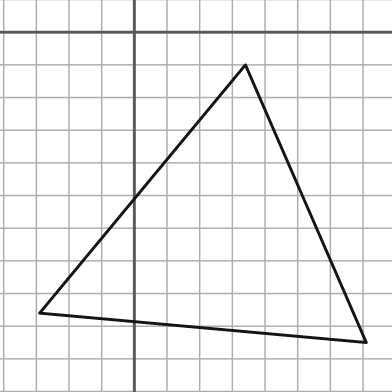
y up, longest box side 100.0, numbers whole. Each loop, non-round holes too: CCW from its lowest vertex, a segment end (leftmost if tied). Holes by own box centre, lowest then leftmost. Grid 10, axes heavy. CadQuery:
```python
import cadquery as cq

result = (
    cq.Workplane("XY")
    .moveTo(71.0, -95.0)
    .lineTo(34.0, -10.0)
    .lineTo(-29.0, -86.0)
    .close()
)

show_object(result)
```